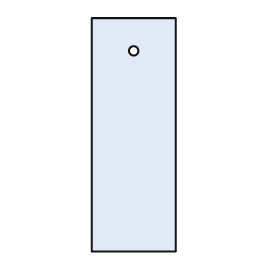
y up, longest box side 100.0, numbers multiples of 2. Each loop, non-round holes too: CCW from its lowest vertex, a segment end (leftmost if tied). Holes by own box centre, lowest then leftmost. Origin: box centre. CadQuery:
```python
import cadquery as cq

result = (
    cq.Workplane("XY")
    .moveTo(-18.0, -50.0)
    .lineTo(18.0, -50.0)
    .lineTo(18.0, 50.0)
    .lineTo(-18.0, 50.0)
    .close()
    .moveTo(0.0, 36.0)
    .circle(2.0)
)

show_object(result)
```